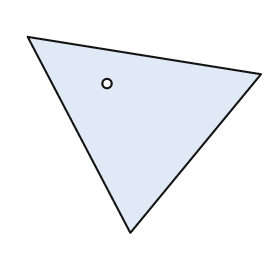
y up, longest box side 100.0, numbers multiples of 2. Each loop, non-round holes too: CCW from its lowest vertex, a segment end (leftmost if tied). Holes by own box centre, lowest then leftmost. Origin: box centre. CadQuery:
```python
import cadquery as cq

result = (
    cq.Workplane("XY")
    .moveTo(-6.0, -42.0)
    .lineTo(50.0, 26.0)
    .lineTo(-50.0, 42.0)
    .close()
    .moveTo(-16.0, 22.0)
    .circle(2.0)
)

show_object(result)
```